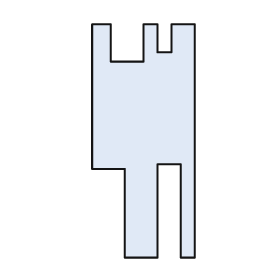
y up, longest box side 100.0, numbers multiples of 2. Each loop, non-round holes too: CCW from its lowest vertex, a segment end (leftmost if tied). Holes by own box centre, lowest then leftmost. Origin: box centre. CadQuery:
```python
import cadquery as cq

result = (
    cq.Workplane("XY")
    .moveTo(-8.0, -50.0)
    .lineTo(6.0, -50.0)
    .lineTo(6.0, -10.0)
    .lineTo(16.0, -10.0)
    .lineTo(16.0, -50.0)
    .lineTo(22.0, -50.0)
    .lineTo(22.0, 50.0)
    .lineTo(12.0, 50.0)
    .lineTo(12.0, 38.0)
    .lineTo(6.0, 38.0)
    .lineTo(6.0, 50.0)
    .lineTo(0.0, 50.0)
    .lineTo(0.0, 34.0)
    .lineTo(-14.0, 34.0)
    .lineTo(-14.0, 50.0)
    .lineTo(-22.0, 50.0)
    .lineTo(-22.0, -12.0)
    .lineTo(-8.0, -12.0)
    .close()
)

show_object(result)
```